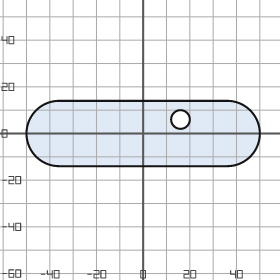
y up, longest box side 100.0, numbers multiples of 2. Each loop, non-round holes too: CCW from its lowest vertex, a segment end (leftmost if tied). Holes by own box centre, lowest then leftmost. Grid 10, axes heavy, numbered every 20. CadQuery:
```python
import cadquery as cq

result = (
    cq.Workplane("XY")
    .moveTo(-36.0, -14.0)
    .lineTo(36.0, -14.0)
    .threePointArc((50.0, 0.0), (36.0, 14.0))
    .lineTo(-36.0, 14.0)
    .threePointArc((-50.0, 0.0), (-36.0, -14.0))
    .close()
    .moveTo(16.0, 6.0)
    .circle(4.0)
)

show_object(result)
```